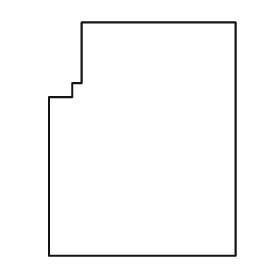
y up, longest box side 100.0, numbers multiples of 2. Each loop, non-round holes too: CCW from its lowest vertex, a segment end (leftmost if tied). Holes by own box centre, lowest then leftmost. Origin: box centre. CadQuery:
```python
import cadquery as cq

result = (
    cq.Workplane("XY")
    .moveTo(-40.0, -50.0)
    .lineTo(40.0, -50.0)
    .lineTo(40.0, 50.0)
    .lineTo(-26.0, 50.0)
    .lineTo(-26.0, 24.0)
    .lineTo(-30.0, 24.0)
    .lineTo(-30.0, 18.0)
    .lineTo(-40.0, 18.0)
    .close()
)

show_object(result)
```